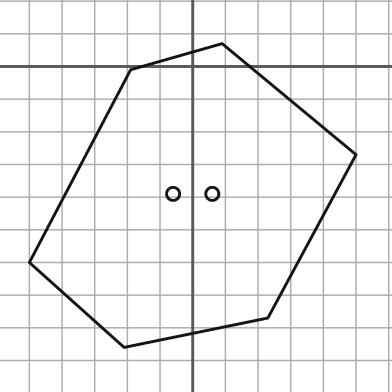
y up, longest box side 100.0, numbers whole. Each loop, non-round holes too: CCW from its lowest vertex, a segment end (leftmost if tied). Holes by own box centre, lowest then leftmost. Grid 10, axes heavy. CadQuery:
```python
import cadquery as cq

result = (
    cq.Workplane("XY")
    .moveTo(-21.0, -86.0)
    .lineTo(23.0, -77.0)
    .lineTo(50.0, -27.0)
    .lineTo(9.0, 7.0)
    .lineTo(-19.0, -1.0)
    .lineTo(-50.0, -60.0)
    .close()
    .moveTo(-6.0, -39.0)
    .circle(2.0)
    .moveTo(6.0, -39.0)
    .circle(2.0)
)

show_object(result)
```